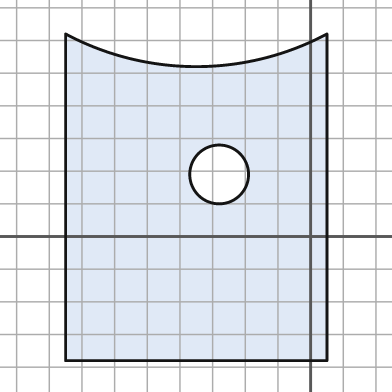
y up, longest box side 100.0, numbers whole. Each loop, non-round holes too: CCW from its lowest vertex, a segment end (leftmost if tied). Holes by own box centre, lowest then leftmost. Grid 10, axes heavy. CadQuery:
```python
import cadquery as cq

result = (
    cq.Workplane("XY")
    .moveTo(-75.0, -38.0)
    .lineTo(5.0, -38.0)
    .lineTo(5.0, 62.0)
    .threePointArc((-35.0, 52.0), (-75.0, 62.0))
    .close()
    .moveTo(-28.0, 19.0)
    .circle(9.0)
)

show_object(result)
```